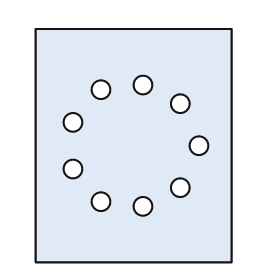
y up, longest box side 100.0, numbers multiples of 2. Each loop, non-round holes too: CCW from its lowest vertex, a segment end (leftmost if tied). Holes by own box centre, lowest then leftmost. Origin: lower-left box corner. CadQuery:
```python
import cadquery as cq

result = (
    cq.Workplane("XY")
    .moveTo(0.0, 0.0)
    .lineTo(84.0, 0.0)
    .lineTo(84.0, 100.0)
    .lineTo(0.0, 100.0)
    .close()
    .moveTo(46.0, 24.0)
    .circle(4.0)
    .moveTo(28.0, 26.0)
    .circle(4.0)
    .moveTo(62.0, 32.0)
    .circle(4.0)
    .moveTo(16.0, 40.0)
    .circle(4.0)
    .moveTo(70.0, 50.0)
    .circle(4.0)
    .moveTo(16.0, 60.0)
    .circle(4.0)
    .moveTo(62.0, 68.0)
    .circle(4.0)
    .moveTo(28.0, 74.0)
    .circle(4.0)
    .moveTo(46.0, 76.0)
    .circle(4.0)
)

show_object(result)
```